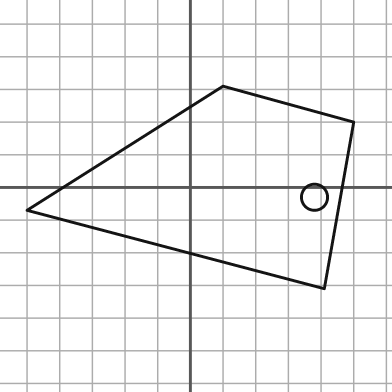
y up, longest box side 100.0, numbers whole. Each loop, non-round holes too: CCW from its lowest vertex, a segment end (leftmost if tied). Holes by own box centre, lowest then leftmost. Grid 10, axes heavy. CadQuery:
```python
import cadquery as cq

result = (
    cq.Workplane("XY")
    .moveTo(41.0, -31.0)
    .lineTo(50.0, 20.0)
    .lineTo(10.0, 31.0)
    .lineTo(-50.0, -7.0)
    .close()
    .moveTo(38.0, -3.0)
    .circle(4.0)
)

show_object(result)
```